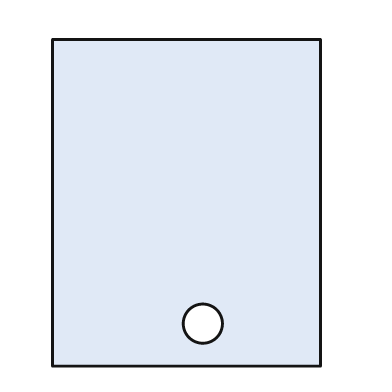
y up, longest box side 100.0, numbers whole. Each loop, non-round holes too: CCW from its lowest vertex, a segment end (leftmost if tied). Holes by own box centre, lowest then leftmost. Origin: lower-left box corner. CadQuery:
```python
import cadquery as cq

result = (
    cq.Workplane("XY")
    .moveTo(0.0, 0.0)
    .lineTo(82.0, 0.0)
    .lineTo(82.0, 100.0)
    .lineTo(0.0, 100.0)
    .close()
    .moveTo(46.0, 13.0)
    .circle(6.0)
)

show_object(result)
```